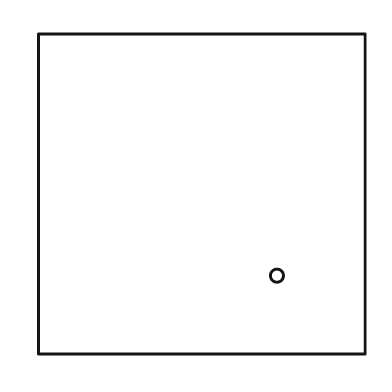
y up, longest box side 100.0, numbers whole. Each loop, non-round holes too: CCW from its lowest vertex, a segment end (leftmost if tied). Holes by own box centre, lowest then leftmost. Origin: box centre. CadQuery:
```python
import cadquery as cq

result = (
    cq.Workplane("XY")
    .moveTo(-50.0, -49.0)
    .lineTo(50.0, -49.0)
    .lineTo(50.0, 49.0)
    .lineTo(-50.0, 49.0)
    .close()
    .moveTo(23.0, -25.0)
    .circle(2.0)
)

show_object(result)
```